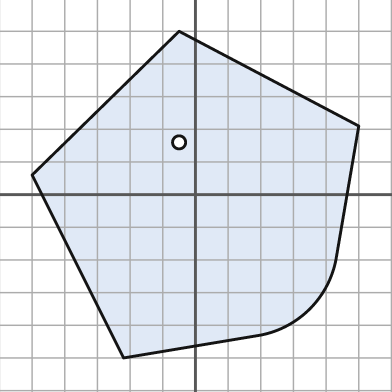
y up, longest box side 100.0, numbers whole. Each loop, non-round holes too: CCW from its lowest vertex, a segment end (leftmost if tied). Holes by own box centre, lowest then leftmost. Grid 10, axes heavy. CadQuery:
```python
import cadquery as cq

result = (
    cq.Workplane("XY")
    .moveTo(-22.0, -50.0)
    .lineTo(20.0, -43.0)
    .threePointArc((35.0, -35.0), (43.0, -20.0))
    .lineTo(50.0, 21.0)
    .lineTo(-5.0, 50.0)
    .lineTo(-50.0, 6.0)
    .close()
    .moveTo(-5.0, 16.0)
    .circle(2.0)
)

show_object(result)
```